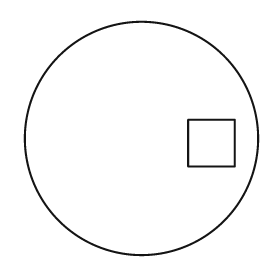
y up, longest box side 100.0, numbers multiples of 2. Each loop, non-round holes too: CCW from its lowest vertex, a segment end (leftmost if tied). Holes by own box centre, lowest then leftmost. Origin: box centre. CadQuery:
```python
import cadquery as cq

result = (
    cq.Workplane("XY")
    .moveTo(0.0, 0.0)
    .circle(50.0)
    .moveTo(20.0, -12.0)
    .lineTo(40.0, -12.0)
    .lineTo(40.0, 8.0)
    .lineTo(20.0, 8.0)
    .close()
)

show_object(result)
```